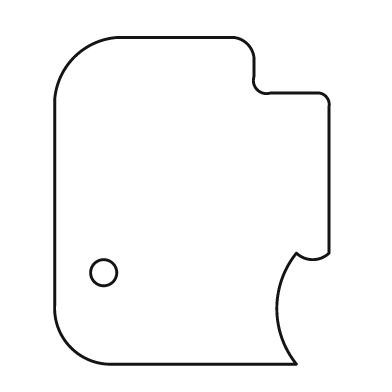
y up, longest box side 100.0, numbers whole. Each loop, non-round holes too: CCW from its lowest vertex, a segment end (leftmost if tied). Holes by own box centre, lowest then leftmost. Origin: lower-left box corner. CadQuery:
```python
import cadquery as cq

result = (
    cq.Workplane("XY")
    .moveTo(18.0, 0.0)
    .lineTo(74.0, 0.0)
    .threePointArc((68.0, 17.0), (74.0, 34.0))
    .threePointArc((79.0, 32.0), (84.0, 34.0))
    .lineTo(84.0, 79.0)
    .threePointArc((83.0, 82.0), (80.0, 83.0))
    .lineTo(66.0, 83.0)
    .threePointArc((62.0, 84.0), (61.0, 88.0))
    .lineTo(61.0, 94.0)
    .threePointArc((59.0, 98.0), (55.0, 100.0))
    .lineTo(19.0, 100.0)
    .threePointArc((6.0, 94.0), (0.0, 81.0))
    .lineTo(0.0, 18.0)
    .threePointArc((5.0, 5.0), (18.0, 0.0))
    .close()
    .moveTo(15.0, 28.0)
    .circle(4.0)
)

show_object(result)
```